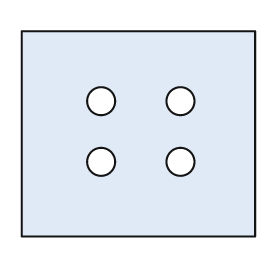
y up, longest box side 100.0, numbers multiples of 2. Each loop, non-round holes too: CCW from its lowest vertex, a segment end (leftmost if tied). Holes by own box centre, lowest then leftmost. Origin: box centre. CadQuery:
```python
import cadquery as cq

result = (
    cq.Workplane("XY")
    .moveTo(-50.0, -44.0)
    .lineTo(50.0, -44.0)
    .lineTo(50.0, 44.0)
    .lineTo(-50.0, 44.0)
    .close()
    .moveTo(-16.0, -12.0)
    .circle(6.0)
    .moveTo(18.0, -12.0)
    .circle(6.0)
    .moveTo(-16.0, 14.0)
    .circle(6.0)
    .moveTo(18.0, 14.0)
    .circle(6.0)
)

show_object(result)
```